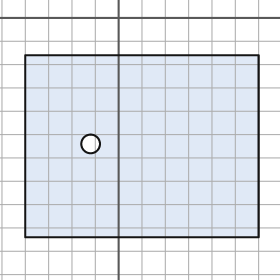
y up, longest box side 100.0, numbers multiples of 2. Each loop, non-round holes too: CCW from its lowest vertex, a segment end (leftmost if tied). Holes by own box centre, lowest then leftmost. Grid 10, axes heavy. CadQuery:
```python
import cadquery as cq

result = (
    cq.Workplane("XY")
    .moveTo(-40.0, -94.0)
    .lineTo(60.0, -94.0)
    .lineTo(60.0, -16.0)
    .lineTo(-40.0, -16.0)
    .close()
    .moveTo(-12.0, -54.0)
    .circle(4.0)
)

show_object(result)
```